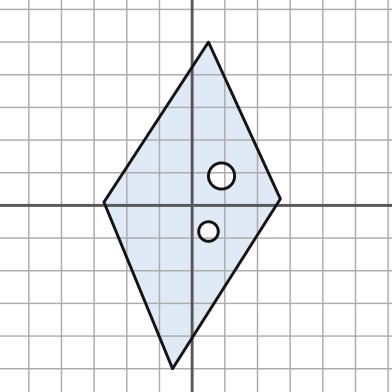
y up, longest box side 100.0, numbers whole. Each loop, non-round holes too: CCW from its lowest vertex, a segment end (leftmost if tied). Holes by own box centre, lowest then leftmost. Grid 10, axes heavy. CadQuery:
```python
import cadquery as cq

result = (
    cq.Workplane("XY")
    .moveTo(-6.0, -50.0)
    .lineTo(27.0, 2.0)
    .lineTo(5.0, 50.0)
    .lineTo(-27.0, 1.0)
    .close()
    .moveTo(5.0, -8.0)
    .circle(3.0)
    .moveTo(9.0, 9.0)
    .circle(4.0)
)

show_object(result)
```